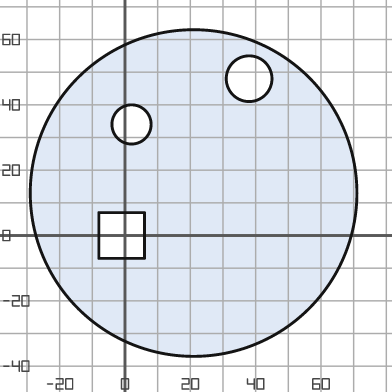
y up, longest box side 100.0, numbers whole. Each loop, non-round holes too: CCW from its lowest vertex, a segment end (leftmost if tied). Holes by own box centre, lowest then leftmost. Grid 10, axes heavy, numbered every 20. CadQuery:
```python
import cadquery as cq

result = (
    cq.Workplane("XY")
    .moveTo(21.0, 13.0)
    .circle(50.0)
    .moveTo(-8.0, -7.0)
    .lineTo(6.0, -7.0)
    .lineTo(6.0, 7.0)
    .lineTo(-8.0, 7.0)
    .close()
    .moveTo(2.0, 34.0)
    .circle(6.0)
    .moveTo(38.0, 48.0)
    .circle(7.0)
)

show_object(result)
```